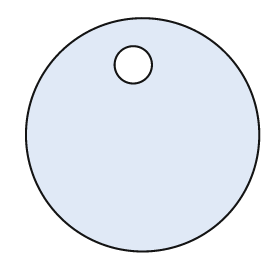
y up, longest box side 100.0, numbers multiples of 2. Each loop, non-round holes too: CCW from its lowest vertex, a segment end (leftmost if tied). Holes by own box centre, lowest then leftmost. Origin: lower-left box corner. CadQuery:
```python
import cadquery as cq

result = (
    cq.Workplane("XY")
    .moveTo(50.0, 50.0)
    .circle(50.0)
    .moveTo(46.0, 80.0)
    .circle(8.0)
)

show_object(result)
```